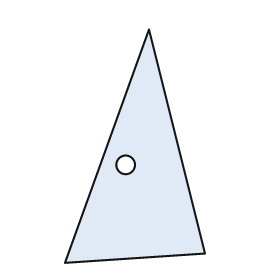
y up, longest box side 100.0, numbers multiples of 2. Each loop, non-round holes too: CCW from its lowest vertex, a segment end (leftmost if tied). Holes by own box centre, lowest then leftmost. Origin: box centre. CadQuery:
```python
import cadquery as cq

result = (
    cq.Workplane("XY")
    .moveTo(-30.0, -50.0)
    .lineTo(30.0, -46.0)
    .lineTo(6.0, 50.0)
    .close()
    .moveTo(-4.0, -8.0)
    .circle(4.0)
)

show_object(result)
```